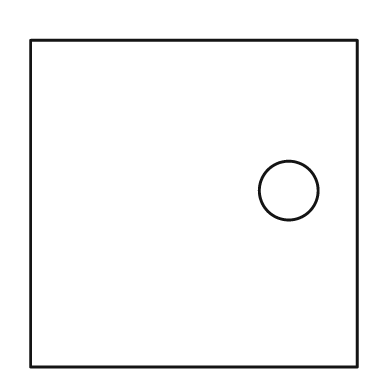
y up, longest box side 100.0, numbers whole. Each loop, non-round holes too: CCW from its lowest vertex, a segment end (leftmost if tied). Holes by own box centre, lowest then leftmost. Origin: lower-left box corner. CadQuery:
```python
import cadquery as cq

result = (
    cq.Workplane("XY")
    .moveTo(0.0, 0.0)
    .lineTo(100.0, 0.0)
    .lineTo(100.0, 100.0)
    .lineTo(0.0, 100.0)
    .close()
    .moveTo(79.0, 54.0)
    .circle(9.0)
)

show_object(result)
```